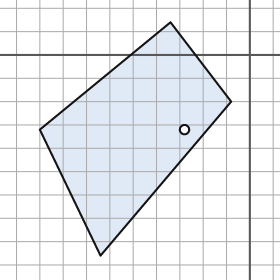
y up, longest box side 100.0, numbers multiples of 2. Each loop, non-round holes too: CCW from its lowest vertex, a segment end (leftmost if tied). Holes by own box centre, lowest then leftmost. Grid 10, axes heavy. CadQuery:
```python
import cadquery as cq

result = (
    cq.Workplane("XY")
    .moveTo(-64.0, -86.0)
    .lineTo(-8.0, -20.0)
    .lineTo(-34.0, 14.0)
    .lineTo(-90.0, -32.0)
    .close()
    .moveTo(-28.0, -32.0)
    .circle(2.0)
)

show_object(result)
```